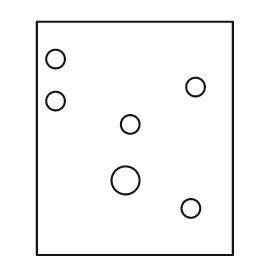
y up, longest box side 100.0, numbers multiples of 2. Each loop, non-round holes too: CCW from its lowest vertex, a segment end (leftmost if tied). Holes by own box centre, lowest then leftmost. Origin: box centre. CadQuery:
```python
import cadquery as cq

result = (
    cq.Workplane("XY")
    .moveTo(-42.0, -50.0)
    .lineTo(42.0, -50.0)
    .lineTo(42.0, 50.0)
    .lineTo(-42.0, 50.0)
    .close()
    .moveTo(24.0, -30.0)
    .circle(4.0)
    .moveTo(-4.0, -18.0)
    .circle(6.0)
    .moveTo(-2.0, 6.0)
    .circle(4.0)
    .moveTo(-34.0, 16.0)
    .circle(4.0)
    .moveTo(26.0, 22.0)
    .circle(4.0)
    .moveTo(-34.0, 34.0)
    .circle(4.0)
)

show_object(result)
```